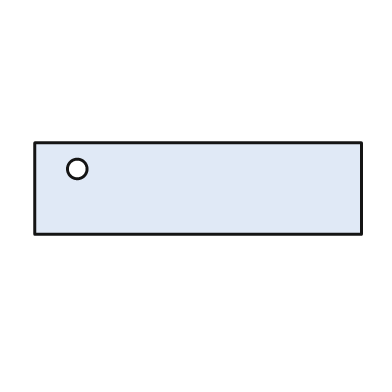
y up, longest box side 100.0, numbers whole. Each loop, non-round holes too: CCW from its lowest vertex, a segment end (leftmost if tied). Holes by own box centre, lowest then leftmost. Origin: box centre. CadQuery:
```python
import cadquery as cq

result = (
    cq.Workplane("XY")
    .moveTo(-50.0, -14.0)
    .lineTo(50.0, -14.0)
    .lineTo(50.0, 14.0)
    .lineTo(-50.0, 14.0)
    .close()
    .moveTo(-37.0, 6.0)
    .circle(3.0)
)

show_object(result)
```